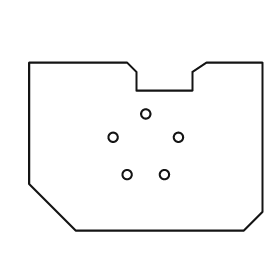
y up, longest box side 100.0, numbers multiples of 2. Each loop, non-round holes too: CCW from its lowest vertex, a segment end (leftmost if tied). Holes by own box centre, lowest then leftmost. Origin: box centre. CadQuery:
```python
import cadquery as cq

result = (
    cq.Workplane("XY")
    .moveTo(-30.0, -36.0)
    .lineTo(42.0, -36.0)
    .lineTo(50.0, -28.0)
    .lineTo(50.0, 36.0)
    .lineTo(26.0, 36.0)
    .lineTo(20.0, 32.0)
    .lineTo(20.0, 24.0)
    .lineTo(-4.0, 24.0)
    .lineTo(-4.0, 32.0)
    .lineTo(-8.0, 36.0)
    .lineTo(-50.0, 36.0)
    .lineTo(-50.0, -16.0)
    .close()
    .moveTo(-8.0, -12.0)
    .circle(2.0)
    .moveTo(8.0, -12.0)
    .circle(2.0)
    .moveTo(-14.0, 4.0)
    .circle(2.0)
    .moveTo(14.0, 4.0)
    .circle(2.0)
    .moveTo(0.0, 14.0)
    .circle(2.0)
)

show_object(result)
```